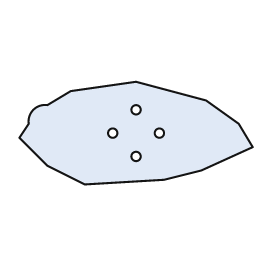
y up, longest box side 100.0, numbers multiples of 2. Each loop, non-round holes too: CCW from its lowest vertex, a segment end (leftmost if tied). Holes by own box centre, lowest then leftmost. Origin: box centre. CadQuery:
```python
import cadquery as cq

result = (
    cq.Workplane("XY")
    .moveTo(-22.0, -22.0)
    .lineTo(12.0, -20.0)
    .lineTo(28.0, -16.0)
    .lineTo(50.0, -6.0)
    .lineTo(44.0, 4.0)
    .lineTo(30.0, 14.0)
    .lineTo(0.0, 22.0)
    .lineTo(-28.0, 18.0)
    .lineTo(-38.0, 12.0)
    .threePointArc((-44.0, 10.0), (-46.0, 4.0))
    .lineTo(-50.0, -2.0)
    .lineTo(-38.0, -14.0)
    .close()
    .moveTo(0.0, -10.0)
    .circle(2.0)
    .moveTo(-10.0, 0.0)
    .circle(2.0)
    .moveTo(10.0, 0.0)
    .circle(2.0)
    .moveTo(0.0, 10.0)
    .circle(2.0)
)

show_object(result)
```